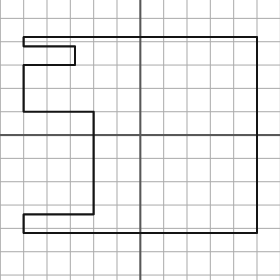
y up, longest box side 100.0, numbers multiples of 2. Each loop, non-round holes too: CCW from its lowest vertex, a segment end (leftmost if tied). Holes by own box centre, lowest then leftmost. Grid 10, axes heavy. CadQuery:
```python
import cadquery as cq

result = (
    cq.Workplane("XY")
    .moveTo(-50.0, -42.0)
    .lineTo(50.0, -42.0)
    .lineTo(50.0, 42.0)
    .lineTo(-50.0, 42.0)
    .lineTo(-50.0, 38.0)
    .lineTo(-28.0, 38.0)
    .lineTo(-28.0, 30.0)
    .lineTo(-50.0, 30.0)
    .lineTo(-50.0, 10.0)
    .lineTo(-20.0, 10.0)
    .lineTo(-20.0, -34.0)
    .lineTo(-50.0, -34.0)
    .close()
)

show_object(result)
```